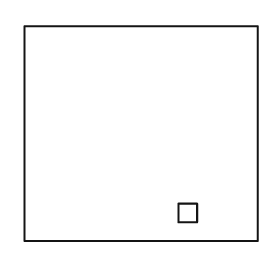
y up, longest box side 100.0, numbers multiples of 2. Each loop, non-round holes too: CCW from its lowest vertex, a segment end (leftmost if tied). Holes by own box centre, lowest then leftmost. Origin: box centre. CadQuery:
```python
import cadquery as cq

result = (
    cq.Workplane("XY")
    .moveTo(-50.0, -46.0)
    .lineTo(50.0, -46.0)
    .lineTo(50.0, 46.0)
    .lineTo(-50.0, 46.0)
    .close()
    .moveTo(16.0, -38.0)
    .lineTo(24.0, -38.0)
    .lineTo(24.0, -30.0)
    .lineTo(16.0, -30.0)
    .close()
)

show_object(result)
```